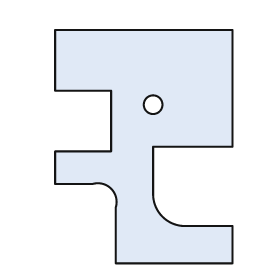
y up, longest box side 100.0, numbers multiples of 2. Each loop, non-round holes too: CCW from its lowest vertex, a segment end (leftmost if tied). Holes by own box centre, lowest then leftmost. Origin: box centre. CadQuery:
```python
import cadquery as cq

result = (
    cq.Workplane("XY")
    .moveTo(-12.0, -50.0)
    .lineTo(38.0, -50.0)
    .lineTo(38.0, -34.0)
    .lineTo(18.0, -34.0)
    .threePointArc((8.0, -30.0), (4.0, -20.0))
    .lineTo(4.0, 0.0)
    .lineTo(38.0, 0.0)
    .lineTo(38.0, 50.0)
    .lineTo(-38.0, 50.0)
    .lineTo(-38.0, 24.0)
    .lineTo(-14.0, 24.0)
    .lineTo(-14.0, -2.0)
    .lineTo(-38.0, -2.0)
    .lineTo(-38.0, -16.0)
    .lineTo(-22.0, -16.0)
    .threePointArc((-14.0, -18.0), (-12.0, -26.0))
    .close()
    .moveTo(4.0, 18.0)
    .circle(4.0)
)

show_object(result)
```